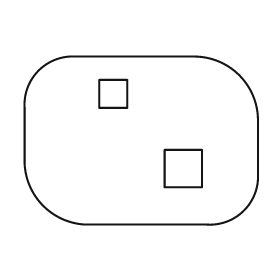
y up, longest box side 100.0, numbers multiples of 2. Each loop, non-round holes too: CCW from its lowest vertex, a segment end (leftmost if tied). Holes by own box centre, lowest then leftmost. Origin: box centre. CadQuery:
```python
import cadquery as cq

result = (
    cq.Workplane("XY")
    .moveTo(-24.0, -36.0)
    .lineTo(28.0, -36.0)
    .threePointArc((44.0, -30.0), (50.0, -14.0))
    .lineTo(50.0, 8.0)
    .threePointArc((42.0, 28.0), (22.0, 36.0))
    .lineTo(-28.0, 36.0)
    .threePointArc((-44.0, 30.0), (-50.0, 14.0))
    .lineTo(-50.0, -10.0)
    .threePointArc((-42.0, -28.0), (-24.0, -36.0))
    .close()
    .moveTo(10.0, -20.0)
    .lineTo(26.0, -20.0)
    .lineTo(26.0, -4.0)
    .lineTo(10.0, -4.0)
    .close()
    .moveTo(-18.0, 14.0)
    .lineTo(-6.0, 14.0)
    .lineTo(-6.0, 26.0)
    .lineTo(-18.0, 26.0)
    .close()
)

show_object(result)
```